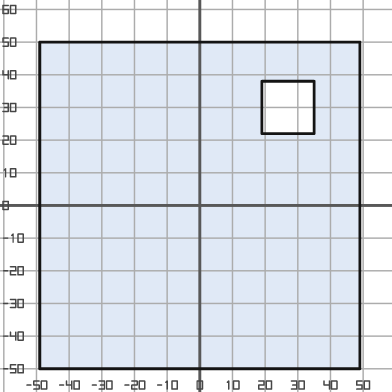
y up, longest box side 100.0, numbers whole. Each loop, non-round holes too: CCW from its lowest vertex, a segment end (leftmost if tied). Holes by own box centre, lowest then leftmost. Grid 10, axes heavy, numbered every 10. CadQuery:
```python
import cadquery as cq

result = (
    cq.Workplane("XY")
    .moveTo(-49.0, -50.0)
    .lineTo(49.0, -50.0)
    .lineTo(49.0, 50.0)
    .lineTo(-49.0, 50.0)
    .close()
    .moveTo(19.0, 22.0)
    .lineTo(35.0, 22.0)
    .lineTo(35.0, 38.0)
    .lineTo(19.0, 38.0)
    .close()
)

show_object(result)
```